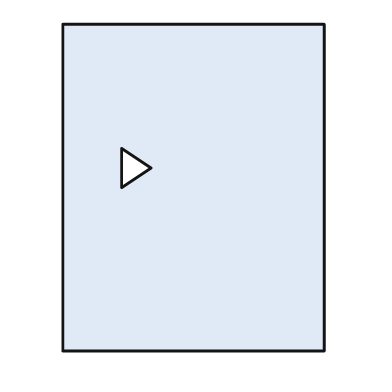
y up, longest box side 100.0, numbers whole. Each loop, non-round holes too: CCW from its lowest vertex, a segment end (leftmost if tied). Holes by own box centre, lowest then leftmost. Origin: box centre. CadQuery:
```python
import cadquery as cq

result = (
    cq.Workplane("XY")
    .moveTo(-40.0, -50.0)
    .lineTo(40.0, -50.0)
    .lineTo(40.0, 50.0)
    .lineTo(-40.0, 50.0)
    .close()
    .moveTo(-22.0, 0.0)
    .lineTo(-13.0, 6.0)
    .lineTo(-22.0, 12.0)
    .close()
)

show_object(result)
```